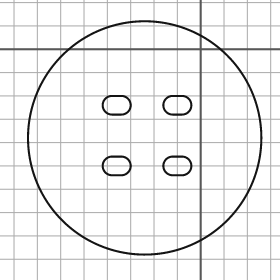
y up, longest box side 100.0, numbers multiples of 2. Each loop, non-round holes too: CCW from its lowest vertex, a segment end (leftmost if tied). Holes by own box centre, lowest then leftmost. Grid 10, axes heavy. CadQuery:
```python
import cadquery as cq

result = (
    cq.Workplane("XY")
    .moveTo(-24.0, -38.0)
    .circle(50.0)
    .moveTo(-38.0, -54.0)
    .lineTo(-34.0, -54.0)
    .threePointArc((-30.0, -50.0), (-34.0, -46.0))
    .lineTo(-38.0, -46.0)
    .threePointArc((-42.0, -50.0), (-38.0, -54.0))
    .close()
    .moveTo(-12.0, -54.0)
    .lineTo(-8.0, -54.0)
    .threePointArc((-4.0, -50.0), (-8.0, -46.0))
    .lineTo(-12.0, -46.0)
    .threePointArc((-16.0, -50.0), (-12.0, -54.0))
    .close()
    .moveTo(-38.0, -28.0)
    .lineTo(-34.0, -28.0)
    .threePointArc((-30.0, -24.0), (-34.0, -20.0))
    .lineTo(-38.0, -20.0)
    .threePointArc((-42.0, -24.0), (-38.0, -28.0))
    .close()
    .moveTo(-12.0, -28.0)
    .lineTo(-8.0, -28.0)
    .threePointArc((-4.0, -24.0), (-8.0, -20.0))
    .lineTo(-12.0, -20.0)
    .threePointArc((-16.0, -24.0), (-12.0, -28.0))
    .close()
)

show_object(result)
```